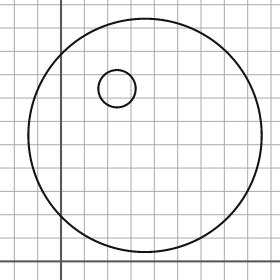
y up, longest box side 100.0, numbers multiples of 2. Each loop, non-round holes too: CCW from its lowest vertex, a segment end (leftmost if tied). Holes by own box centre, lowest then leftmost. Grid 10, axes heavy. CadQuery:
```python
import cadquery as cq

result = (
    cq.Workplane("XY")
    .moveTo(36.0, 54.0)
    .circle(50.0)
    .moveTo(24.0, 74.0)
    .circle(8.0)
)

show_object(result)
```